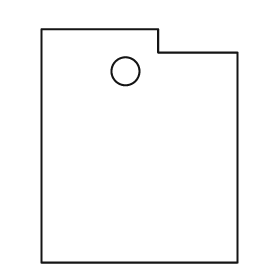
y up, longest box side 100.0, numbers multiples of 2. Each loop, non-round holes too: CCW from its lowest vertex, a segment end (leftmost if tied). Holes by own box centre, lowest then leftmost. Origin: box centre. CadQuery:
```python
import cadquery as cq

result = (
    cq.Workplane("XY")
    .moveTo(-42.0, -50.0)
    .lineTo(42.0, -50.0)
    .lineTo(42.0, 40.0)
    .lineTo(8.0, 40.0)
    .lineTo(8.0, 50.0)
    .lineTo(-42.0, 50.0)
    .close()
    .moveTo(-6.0, 32.0)
    .circle(6.0)
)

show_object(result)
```